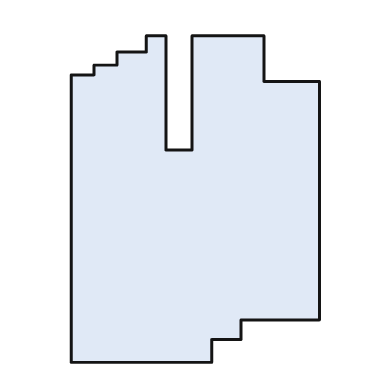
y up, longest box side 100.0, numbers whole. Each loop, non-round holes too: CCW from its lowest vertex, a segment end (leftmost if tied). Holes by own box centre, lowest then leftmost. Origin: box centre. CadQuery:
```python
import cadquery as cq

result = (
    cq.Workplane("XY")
    .moveTo(-38.0, -50.0)
    .lineTo(5.0, -50.0)
    .lineTo(5.0, -43.0)
    .lineTo(14.0, -43.0)
    .lineTo(14.0, -37.0)
    .lineTo(38.0, -37.0)
    .lineTo(38.0, 36.0)
    .lineTo(21.0, 36.0)
    .lineTo(21.0, 50.0)
    .lineTo(-1.0, 50.0)
    .lineTo(-1.0, 15.0)
    .lineTo(-9.0, 15.0)
    .lineTo(-9.0, 50.0)
    .lineTo(-15.0, 50.0)
    .lineTo(-15.0, 45.0)
    .lineTo(-24.0, 45.0)
    .lineTo(-24.0, 41.0)
    .lineTo(-31.0, 41.0)
    .lineTo(-31.0, 38.0)
    .lineTo(-38.0, 38.0)
    .close()
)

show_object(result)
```